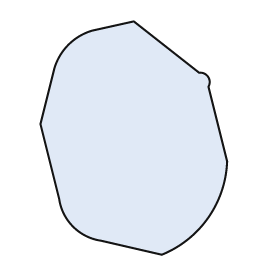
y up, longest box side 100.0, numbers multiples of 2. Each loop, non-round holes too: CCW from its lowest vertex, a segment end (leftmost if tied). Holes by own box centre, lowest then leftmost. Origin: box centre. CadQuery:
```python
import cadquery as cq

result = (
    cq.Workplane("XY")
    .moveTo(12.0, -50.0)
    .threePointArc((32.0, -34.0), (40.0, -10.0))
    .lineTo(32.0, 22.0)
    .threePointArc((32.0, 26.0), (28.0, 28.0))
    .lineTo(0.0, 50.0)
    .lineTo(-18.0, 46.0)
    .threePointArc((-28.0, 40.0), (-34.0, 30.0))
    .lineTo(-40.0, 6.0)
    .lineTo(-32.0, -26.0)
    .threePointArc((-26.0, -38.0), (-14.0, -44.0))
    .close()
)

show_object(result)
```